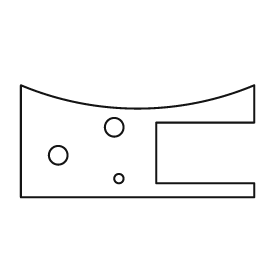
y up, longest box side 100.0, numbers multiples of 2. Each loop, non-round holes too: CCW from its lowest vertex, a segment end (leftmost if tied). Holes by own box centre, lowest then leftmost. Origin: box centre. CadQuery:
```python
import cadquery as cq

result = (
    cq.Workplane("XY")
    .moveTo(-50.0, -24.0)
    .lineTo(50.0, -24.0)
    .lineTo(50.0, -18.0)
    .lineTo(8.0, -18.0)
    .lineTo(8.0, 8.0)
    .lineTo(50.0, 8.0)
    .lineTo(50.0, 24.0)
    .threePointArc((0.0, 14.0), (-50.0, 24.0))
    .close()
    .moveTo(-8.0, -16.0)
    .circle(2.0)
    .moveTo(-34.0, -6.0)
    .circle(4.0)
    .moveTo(-10.0, 6.0)
    .circle(4.0)
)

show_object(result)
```